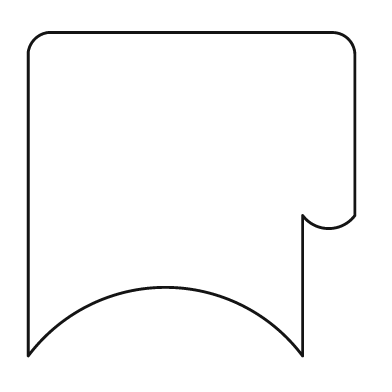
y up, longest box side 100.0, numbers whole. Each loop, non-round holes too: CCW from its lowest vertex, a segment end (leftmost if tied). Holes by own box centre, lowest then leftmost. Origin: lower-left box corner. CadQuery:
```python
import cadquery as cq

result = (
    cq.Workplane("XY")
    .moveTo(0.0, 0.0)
    .threePointArc((42.0, 21.0), (84.0, 0.0))
    .lineTo(84.0, 43.0)
    .threePointArc((92.0, 39.0), (100.0, 43.0))
    .lineTo(100.0, 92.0)
    .threePointArc((98.0, 97.0), (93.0, 99.0))
    .lineTo(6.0, 99.0)
    .threePointArc((2.0, 97.0), (0.0, 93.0))
    .close()
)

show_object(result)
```